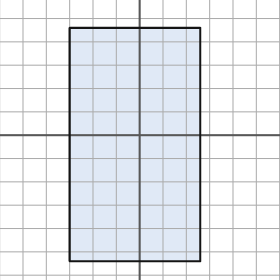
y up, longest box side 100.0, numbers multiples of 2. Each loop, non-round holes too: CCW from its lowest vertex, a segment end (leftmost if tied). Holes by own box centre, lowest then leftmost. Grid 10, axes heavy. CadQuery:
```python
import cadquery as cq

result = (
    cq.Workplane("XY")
    .moveTo(-30.0, -54.0)
    .lineTo(26.0, -54.0)
    .lineTo(26.0, 46.0)
    .lineTo(-30.0, 46.0)
    .close()
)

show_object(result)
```